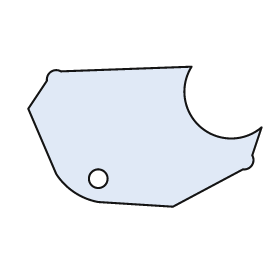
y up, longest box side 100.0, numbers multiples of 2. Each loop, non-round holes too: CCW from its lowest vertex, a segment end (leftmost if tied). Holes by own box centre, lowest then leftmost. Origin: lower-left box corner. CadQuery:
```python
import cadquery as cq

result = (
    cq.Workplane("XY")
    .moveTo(62.0, 0.0)
    .lineTo(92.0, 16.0)
    .threePointArc((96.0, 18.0), (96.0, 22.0))
    .lineTo(100.0, 34.0)
    .threePointArc((74.0, 34.0), (70.0, 60.0))
    .lineTo(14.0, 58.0)
    .threePointArc((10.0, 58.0), (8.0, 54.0))
    .lineTo(0.0, 42.0)
    .lineTo(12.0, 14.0)
    .threePointArc((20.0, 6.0), (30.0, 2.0))
    .close()
    .moveTo(30.0, 12.0)
    .circle(4.0)
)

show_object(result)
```